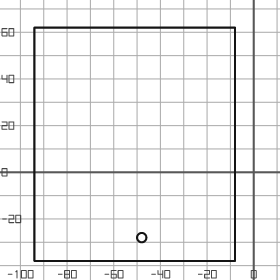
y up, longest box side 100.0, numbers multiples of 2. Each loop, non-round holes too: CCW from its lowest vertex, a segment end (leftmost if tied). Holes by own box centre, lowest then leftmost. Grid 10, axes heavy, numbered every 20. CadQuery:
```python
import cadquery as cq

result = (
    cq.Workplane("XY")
    .moveTo(-94.0, -38.0)
    .lineTo(-8.0, -38.0)
    .lineTo(-8.0, 62.0)
    .lineTo(-94.0, 62.0)
    .close()
    .moveTo(-48.0, -28.0)
    .circle(2.0)
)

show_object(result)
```